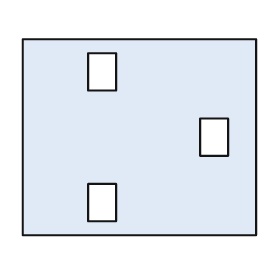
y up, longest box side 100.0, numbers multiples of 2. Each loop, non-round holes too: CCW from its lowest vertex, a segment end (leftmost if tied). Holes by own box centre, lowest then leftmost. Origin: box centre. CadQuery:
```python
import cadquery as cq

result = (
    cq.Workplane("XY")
    .moveTo(-50.0, -42.0)
    .lineTo(50.0, -42.0)
    .lineTo(50.0, 42.0)
    .lineTo(-50.0, 42.0)
    .close()
    .moveTo(-22.0, -36.0)
    .lineTo(-10.0, -36.0)
    .lineTo(-10.0, -20.0)
    .lineTo(-22.0, -20.0)
    .close()
    .moveTo(26.0, -8.0)
    .lineTo(38.0, -8.0)
    .lineTo(38.0, 8.0)
    .lineTo(26.0, 8.0)
    .close()
    .moveTo(-22.0, 20.0)
    .lineTo(-10.0, 20.0)
    .lineTo(-10.0, 36.0)
    .lineTo(-22.0, 36.0)
    .close()
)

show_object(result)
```